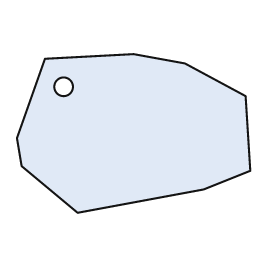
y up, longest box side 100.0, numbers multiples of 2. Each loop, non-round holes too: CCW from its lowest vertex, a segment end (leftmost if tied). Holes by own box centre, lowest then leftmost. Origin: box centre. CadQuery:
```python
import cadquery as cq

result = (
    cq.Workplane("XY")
    .moveTo(-24.0, -34.0)
    .lineTo(30.0, -24.0)
    .lineTo(50.0, -16.0)
    .lineTo(48.0, 16.0)
    .lineTo(22.0, 30.0)
    .lineTo(0.0, 34.0)
    .lineTo(-38.0, 32.0)
    .lineTo(-50.0, -2.0)
    .lineTo(-48.0, -14.0)
    .close()
    .moveTo(-30.0, 20.0)
    .circle(4.0)
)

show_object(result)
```